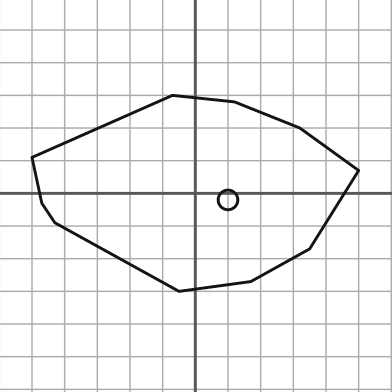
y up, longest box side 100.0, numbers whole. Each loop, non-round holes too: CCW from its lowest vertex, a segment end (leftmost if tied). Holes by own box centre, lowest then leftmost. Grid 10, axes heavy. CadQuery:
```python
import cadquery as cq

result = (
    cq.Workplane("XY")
    .moveTo(-5.0, -30.0)
    .lineTo(17.0, -27.0)
    .lineTo(35.0, -17.0)
    .lineTo(50.0, 7.0)
    .lineTo(32.0, 20.0)
    .lineTo(12.0, 28.0)
    .lineTo(-7.0, 30.0)
    .lineTo(-50.0, 11.0)
    .lineTo(-47.0, -3.0)
    .lineTo(-43.0, -9.0)
    .close()
    .moveTo(10.0, -2.0)
    .circle(3.0)
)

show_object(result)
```